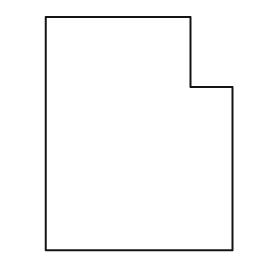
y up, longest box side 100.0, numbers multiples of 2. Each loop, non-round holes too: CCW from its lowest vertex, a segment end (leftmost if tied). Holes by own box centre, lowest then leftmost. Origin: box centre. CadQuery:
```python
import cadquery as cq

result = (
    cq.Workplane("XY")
    .moveTo(-40.0, -50.0)
    .lineTo(40.0, -50.0)
    .lineTo(40.0, 20.0)
    .lineTo(22.0, 20.0)
    .lineTo(22.0, 50.0)
    .lineTo(-40.0, 50.0)
    .close()
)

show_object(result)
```